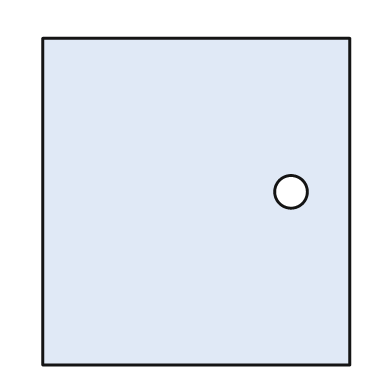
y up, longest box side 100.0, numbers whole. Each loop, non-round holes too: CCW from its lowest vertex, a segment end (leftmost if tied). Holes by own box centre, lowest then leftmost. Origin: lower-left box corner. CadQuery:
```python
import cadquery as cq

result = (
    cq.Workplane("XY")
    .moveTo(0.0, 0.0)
    .lineTo(94.0, 0.0)
    .lineTo(94.0, 100.0)
    .lineTo(0.0, 100.0)
    .close()
    .moveTo(76.0, 53.0)
    .circle(5.0)
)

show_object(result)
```